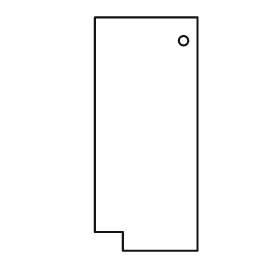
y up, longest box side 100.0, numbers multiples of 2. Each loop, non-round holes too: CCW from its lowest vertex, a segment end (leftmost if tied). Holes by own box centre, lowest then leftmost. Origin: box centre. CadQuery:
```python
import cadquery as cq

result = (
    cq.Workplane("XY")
    .moveTo(-10.0, -50.0)
    .lineTo(22.0, -50.0)
    .lineTo(22.0, 50.0)
    .lineTo(-22.0, 50.0)
    .lineTo(-22.0, -42.0)
    .lineTo(-10.0, -42.0)
    .close()
    .moveTo(16.0, 40.0)
    .circle(2.0)
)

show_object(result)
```